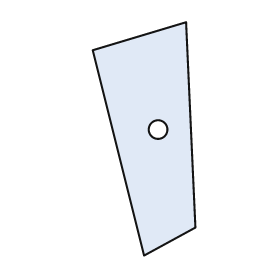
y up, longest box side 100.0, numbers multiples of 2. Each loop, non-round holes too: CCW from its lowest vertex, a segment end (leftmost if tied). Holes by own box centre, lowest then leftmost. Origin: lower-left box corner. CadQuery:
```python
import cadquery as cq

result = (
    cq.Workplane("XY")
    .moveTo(22.0, 0.0)
    .lineTo(44.0, 12.0)
    .lineTo(40.0, 100.0)
    .lineTo(0.0, 88.0)
    .close()
    .moveTo(28.0, 54.0)
    .circle(4.0)
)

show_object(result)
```